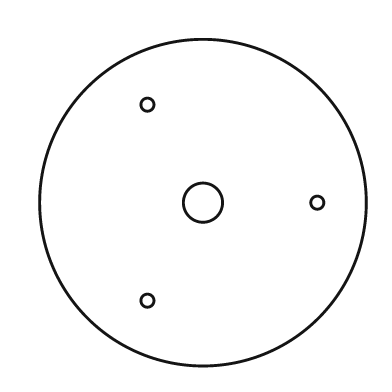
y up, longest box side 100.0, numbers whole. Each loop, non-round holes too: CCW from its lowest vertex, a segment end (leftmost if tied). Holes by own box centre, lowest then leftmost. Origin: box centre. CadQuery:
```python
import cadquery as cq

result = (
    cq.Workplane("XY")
    .moveTo(0.0, 0.0)
    .circle(50.0)
    .moveTo(-17.0, -30.0)
    .circle(2.0)
    .moveTo(0.0, 0.0)
    .circle(6.0)
    .moveTo(35.0, 0.0)
    .circle(2.0)
    .moveTo(-17.0, 30.0)
    .circle(2.0)
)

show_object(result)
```